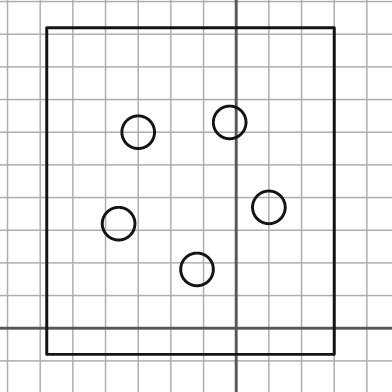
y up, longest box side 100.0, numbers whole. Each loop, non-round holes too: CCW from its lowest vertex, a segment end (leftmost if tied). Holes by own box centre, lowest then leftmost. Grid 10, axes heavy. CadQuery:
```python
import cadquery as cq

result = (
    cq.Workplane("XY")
    .moveTo(-58.0, -8.0)
    .lineTo(30.0, -8.0)
    .lineTo(30.0, 92.0)
    .lineTo(-58.0, 92.0)
    .close()
    .moveTo(-12.0, 18.0)
    .circle(5.0)
    .moveTo(-36.0, 32.0)
    .circle(5.0)
    .moveTo(10.0, 37.0)
    .circle(5.0)
    .moveTo(-30.0, 60.0)
    .circle(5.0)
    .moveTo(-2.0, 63.0)
    .circle(5.0)
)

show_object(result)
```